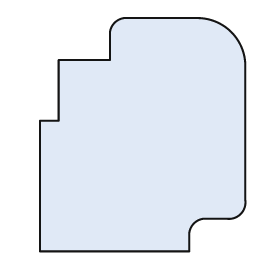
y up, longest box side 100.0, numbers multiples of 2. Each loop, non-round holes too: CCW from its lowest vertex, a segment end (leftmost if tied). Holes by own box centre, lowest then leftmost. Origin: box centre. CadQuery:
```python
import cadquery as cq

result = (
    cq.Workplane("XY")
    .moveTo(-44.0, -50.0)
    .lineTo(20.0, -50.0)
    .lineTo(20.0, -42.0)
    .threePointArc((22.0, -38.0), (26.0, -36.0))
    .lineTo(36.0, -36.0)
    .threePointArc((42.0, -34.0), (44.0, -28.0))
    .lineTo(44.0, 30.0)
    .threePointArc((38.0, 44.0), (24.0, 50.0))
    .lineTo(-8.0, 50.0)
    .threePointArc((-12.0, 48.0), (-14.0, 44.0))
    .lineTo(-14.0, 32.0)
    .lineTo(-36.0, 32.0)
    .lineTo(-36.0, 6.0)
    .lineTo(-44.0, 6.0)
    .close()
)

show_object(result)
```